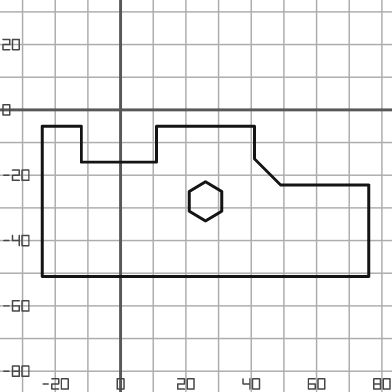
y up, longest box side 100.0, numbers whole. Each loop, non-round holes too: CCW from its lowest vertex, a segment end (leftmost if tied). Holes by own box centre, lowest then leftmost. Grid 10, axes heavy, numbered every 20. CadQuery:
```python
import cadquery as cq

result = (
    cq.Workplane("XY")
    .moveTo(-24.0, -51.0)
    .lineTo(76.0, -51.0)
    .lineTo(76.0, -23.0)
    .lineTo(49.0, -23.0)
    .lineTo(41.0, -15.0)
    .lineTo(41.0, -5.0)
    .lineTo(11.0, -5.0)
    .lineTo(11.0, -16.0)
    .lineTo(-12.0, -16.0)
    .lineTo(-12.0, -5.0)
    .lineTo(-24.0, -5.0)
    .close()
    .moveTo(26.0, -34.0)
    .lineTo(31.0, -31.0)
    .lineTo(31.0, -25.0)
    .lineTo(26.0, -22.0)
    .lineTo(21.0, -25.0)
    .lineTo(21.0, -31.0)
    .close()
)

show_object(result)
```